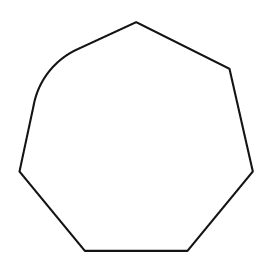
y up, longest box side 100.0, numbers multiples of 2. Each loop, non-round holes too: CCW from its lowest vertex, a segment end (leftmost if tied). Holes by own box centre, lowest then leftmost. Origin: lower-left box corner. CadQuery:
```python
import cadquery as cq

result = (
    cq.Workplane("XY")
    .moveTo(28.0, 0.0)
    .lineTo(72.0, 0.0)
    .lineTo(100.0, 34.0)
    .lineTo(90.0, 78.0)
    .lineTo(50.0, 98.0)
    .lineTo(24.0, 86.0)
    .threePointArc((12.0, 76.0), (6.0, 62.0))
    .lineTo(0.0, 34.0)
    .close()
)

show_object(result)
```